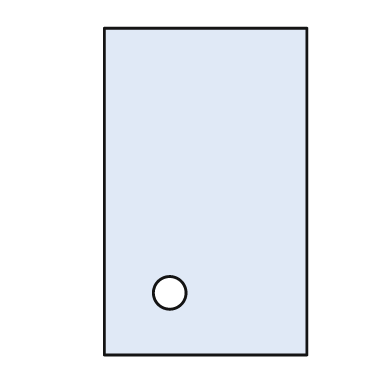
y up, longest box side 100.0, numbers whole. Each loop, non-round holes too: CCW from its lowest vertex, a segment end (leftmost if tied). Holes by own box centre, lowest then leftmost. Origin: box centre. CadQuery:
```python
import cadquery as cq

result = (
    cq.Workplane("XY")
    .moveTo(-31.0, -50.0)
    .lineTo(31.0, -50.0)
    .lineTo(31.0, 50.0)
    .lineTo(-31.0, 50.0)
    .close()
    .moveTo(-11.0, -31.0)
    .circle(5.0)
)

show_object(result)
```